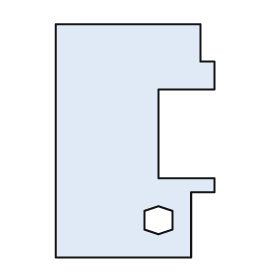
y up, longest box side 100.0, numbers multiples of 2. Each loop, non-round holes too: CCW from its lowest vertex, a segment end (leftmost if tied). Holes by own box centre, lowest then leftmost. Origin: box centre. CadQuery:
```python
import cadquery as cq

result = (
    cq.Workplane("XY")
    .moveTo(-34.0, -50.0)
    .lineTo(24.0, -50.0)
    .lineTo(24.0, -22.0)
    .lineTo(34.0, -22.0)
    .lineTo(34.0, -16.0)
    .lineTo(10.0, -16.0)
    .lineTo(10.0, 22.0)
    .lineTo(34.0, 22.0)
    .lineTo(34.0, 34.0)
    .lineTo(28.0, 34.0)
    .lineTo(28.0, 50.0)
    .lineTo(-34.0, 50.0)
    .close()
    .moveTo(10.0, -40.0)
    .lineTo(16.0, -38.0)
    .lineTo(16.0, -30.0)
    .lineTo(10.0, -28.0)
    .lineTo(4.0, -30.0)
    .lineTo(4.0, -38.0)
    .close()
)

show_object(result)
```